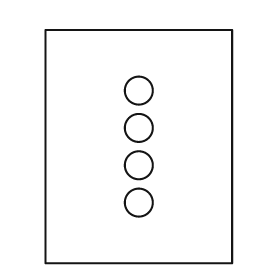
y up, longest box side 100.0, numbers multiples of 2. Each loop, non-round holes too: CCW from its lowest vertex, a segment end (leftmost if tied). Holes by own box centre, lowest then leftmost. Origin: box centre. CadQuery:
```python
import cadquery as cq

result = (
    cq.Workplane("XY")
    .moveTo(-40.0, -50.0)
    .lineTo(40.0, -50.0)
    .lineTo(40.0, 50.0)
    .lineTo(-40.0, 50.0)
    .close()
    .moveTo(0.0, -24.0)
    .circle(6.0)
    .moveTo(0.0, -8.0)
    .circle(6.0)
    .moveTo(0.0, 8.0)
    .circle(6.0)
    .moveTo(0.0, 24.0)
    .circle(6.0)
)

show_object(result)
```